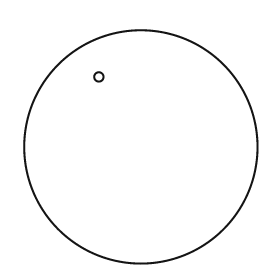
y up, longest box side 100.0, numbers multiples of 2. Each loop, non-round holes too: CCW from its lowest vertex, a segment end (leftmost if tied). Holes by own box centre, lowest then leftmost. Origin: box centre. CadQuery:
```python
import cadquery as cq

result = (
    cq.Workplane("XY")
    .moveTo(0.0, 0.0)
    .circle(50.0)
    .moveTo(-18.0, 30.0)
    .circle(2.0)
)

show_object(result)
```